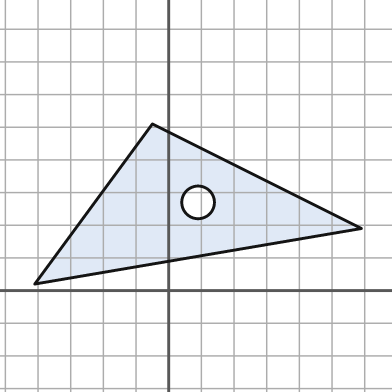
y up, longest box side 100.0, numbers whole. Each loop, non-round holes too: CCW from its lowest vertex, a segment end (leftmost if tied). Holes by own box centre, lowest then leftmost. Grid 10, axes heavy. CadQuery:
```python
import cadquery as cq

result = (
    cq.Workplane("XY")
    .moveTo(-41.0, 2.0)
    .lineTo(59.0, 19.0)
    .lineTo(-5.0, 51.0)
    .close()
    .moveTo(9.0, 27.0)
    .circle(5.0)
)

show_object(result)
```